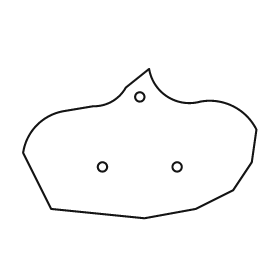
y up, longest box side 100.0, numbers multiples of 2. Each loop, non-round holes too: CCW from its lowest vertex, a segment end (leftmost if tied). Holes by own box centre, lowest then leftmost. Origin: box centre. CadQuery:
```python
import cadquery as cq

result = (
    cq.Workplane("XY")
    .moveTo(2.0, -32.0)
    .lineTo(24.0, -28.0)
    .lineTo(40.0, -20.0)
    .lineTo(48.0, -8.0)
    .lineTo(50.0, 6.0)
    .threePointArc((40.0, 16.0), (26.0, 18.0))
    .threePointArc((12.0, 20.0), (4.0, 32.0))
    .lineTo(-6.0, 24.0)
    .threePointArc((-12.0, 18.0), (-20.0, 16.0))
    .lineTo(-32.0, 14.0)
    .threePointArc((-44.0, 8.0), (-50.0, -4.0))
    .lineTo(-38.0, -28.0)
    .close()
    .moveTo(-16.0, -10.0)
    .circle(2.0)
    .moveTo(16.0, -10.0)
    .circle(2.0)
    .moveTo(0.0, 20.0)
    .circle(2.0)
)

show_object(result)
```